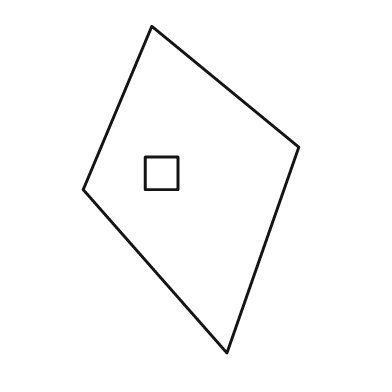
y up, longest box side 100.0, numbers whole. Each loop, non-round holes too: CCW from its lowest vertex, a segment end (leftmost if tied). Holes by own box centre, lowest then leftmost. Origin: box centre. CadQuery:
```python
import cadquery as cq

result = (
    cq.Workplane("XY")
    .moveTo(11.0, -50.0)
    .lineTo(33.0, 13.0)
    .lineTo(-12.0, 50.0)
    .lineTo(-33.0, 0.0)
    .close()
    .moveTo(-14.0, 0.0)
    .lineTo(-4.0, 0.0)
    .lineTo(-4.0, 10.0)
    .lineTo(-14.0, 10.0)
    .close()
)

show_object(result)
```